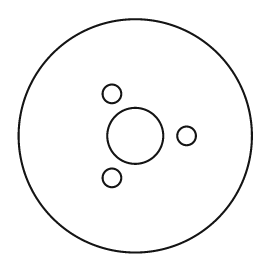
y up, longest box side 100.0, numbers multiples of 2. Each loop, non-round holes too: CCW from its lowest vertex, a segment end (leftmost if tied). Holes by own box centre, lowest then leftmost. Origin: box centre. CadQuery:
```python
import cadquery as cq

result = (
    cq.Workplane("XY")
    .moveTo(0.0, 0.0)
    .circle(50.0)
    .moveTo(-10.0, -18.0)
    .circle(4.0)
    .moveTo(0.0, 0.0)
    .circle(12.0)
    .moveTo(22.0, 0.0)
    .circle(4.0)
    .moveTo(-10.0, 18.0)
    .circle(4.0)
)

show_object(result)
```